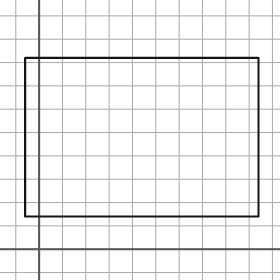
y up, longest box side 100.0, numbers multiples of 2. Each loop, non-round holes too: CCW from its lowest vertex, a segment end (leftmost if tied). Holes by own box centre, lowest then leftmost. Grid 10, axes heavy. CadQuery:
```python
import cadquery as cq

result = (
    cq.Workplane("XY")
    .moveTo(-6.0, 14.0)
    .lineTo(94.0, 14.0)
    .lineTo(94.0, 82.0)
    .lineTo(-6.0, 82.0)
    .close()
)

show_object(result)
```